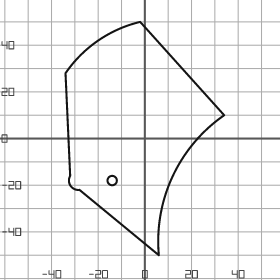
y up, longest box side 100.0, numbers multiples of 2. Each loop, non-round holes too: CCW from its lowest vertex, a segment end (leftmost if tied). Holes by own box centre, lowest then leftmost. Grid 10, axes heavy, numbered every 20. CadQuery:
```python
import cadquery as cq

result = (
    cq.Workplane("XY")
    .moveTo(6.0, -50.0)
    .threePointArc((12.0, -16.0), (34.0, 10.0))
    .lineTo(-2.0, 50.0)
    .threePointArc((-20.0, 42.0), (-34.0, 28.0))
    .lineTo(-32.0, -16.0)
    .threePointArc((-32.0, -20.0), (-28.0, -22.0))
    .close()
    .moveTo(-14.0, -18.0)
    .circle(2.0)
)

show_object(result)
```